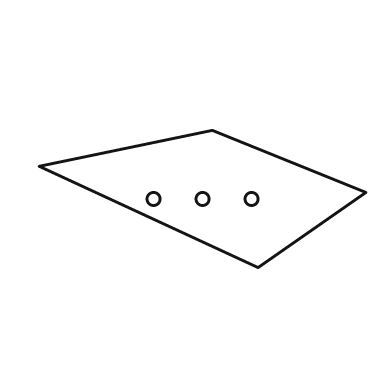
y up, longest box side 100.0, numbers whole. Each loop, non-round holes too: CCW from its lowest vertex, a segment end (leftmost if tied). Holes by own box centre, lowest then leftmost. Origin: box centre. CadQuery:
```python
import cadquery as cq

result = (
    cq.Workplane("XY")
    .moveTo(17.0, -21.0)
    .lineTo(50.0, 2.0)
    .lineTo(3.0, 21.0)
    .lineTo(-50.0, 10.0)
    .close()
    .moveTo(-15.0, 0.0)
    .circle(2.0)
    .moveTo(0.0, 0.0)
    .circle(2.0)
    .moveTo(15.0, 0.0)
    .circle(2.0)
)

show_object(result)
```